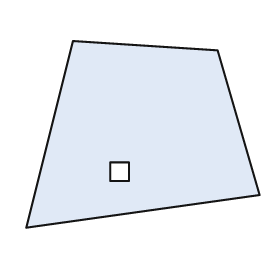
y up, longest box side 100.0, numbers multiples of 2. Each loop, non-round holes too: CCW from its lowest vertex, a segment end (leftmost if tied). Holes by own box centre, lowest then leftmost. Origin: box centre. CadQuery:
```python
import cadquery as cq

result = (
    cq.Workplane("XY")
    .moveTo(-50.0, -40.0)
    .lineTo(50.0, -26.0)
    .lineTo(32.0, 36.0)
    .lineTo(-30.0, 40.0)
    .close()
    .moveTo(-14.0, -20.0)
    .lineTo(-6.0, -20.0)
    .lineTo(-6.0, -12.0)
    .lineTo(-14.0, -12.0)
    .close()
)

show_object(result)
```